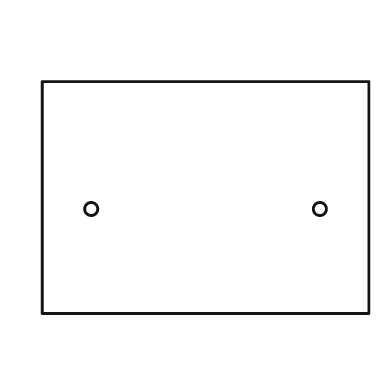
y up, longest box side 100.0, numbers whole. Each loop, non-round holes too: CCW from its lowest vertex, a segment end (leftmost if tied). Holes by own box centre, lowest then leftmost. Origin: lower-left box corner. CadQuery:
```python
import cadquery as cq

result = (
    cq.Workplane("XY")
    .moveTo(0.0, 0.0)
    .lineTo(100.0, 0.0)
    .lineTo(100.0, 71.0)
    .lineTo(0.0, 71.0)
    .close()
    .moveTo(15.0, 32.0)
    .circle(2.0)
    .moveTo(85.0, 32.0)
    .circle(2.0)
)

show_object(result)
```